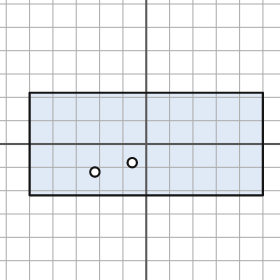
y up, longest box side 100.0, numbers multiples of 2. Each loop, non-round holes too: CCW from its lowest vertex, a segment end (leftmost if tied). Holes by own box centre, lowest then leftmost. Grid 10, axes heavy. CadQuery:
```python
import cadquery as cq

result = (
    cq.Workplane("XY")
    .moveTo(-50.0, -22.0)
    .lineTo(50.0, -22.0)
    .lineTo(50.0, 22.0)
    .lineTo(-50.0, 22.0)
    .close()
    .moveTo(-22.0, -12.0)
    .circle(2.0)
    .moveTo(-6.0, -8.0)
    .circle(2.0)
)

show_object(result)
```